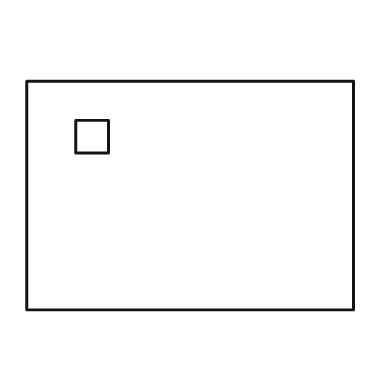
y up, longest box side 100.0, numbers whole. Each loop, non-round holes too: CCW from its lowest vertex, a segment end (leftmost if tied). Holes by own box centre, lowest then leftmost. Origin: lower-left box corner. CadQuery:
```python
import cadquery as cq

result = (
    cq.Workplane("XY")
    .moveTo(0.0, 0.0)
    .lineTo(100.0, 0.0)
    .lineTo(100.0, 70.0)
    .lineTo(0.0, 70.0)
    .close()
    .moveTo(15.0, 48.0)
    .lineTo(25.0, 48.0)
    .lineTo(25.0, 58.0)
    .lineTo(15.0, 58.0)
    .close()
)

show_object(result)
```